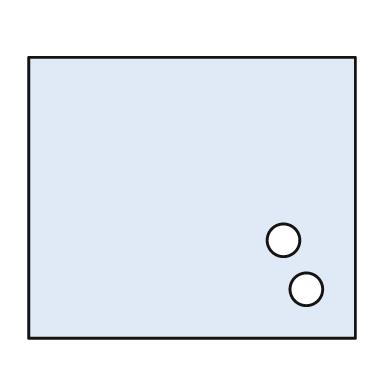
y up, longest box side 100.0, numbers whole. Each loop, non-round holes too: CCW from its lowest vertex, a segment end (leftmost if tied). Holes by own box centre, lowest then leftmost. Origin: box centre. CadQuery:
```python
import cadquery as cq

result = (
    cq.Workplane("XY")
    .moveTo(-50.0, -43.0)
    .lineTo(50.0, -43.0)
    .lineTo(50.0, 43.0)
    .lineTo(-50.0, 43.0)
    .close()
    .moveTo(35.0, -28.0)
    .circle(5.0)
    .moveTo(28.0, -13.0)
    .circle(5.0)
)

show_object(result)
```